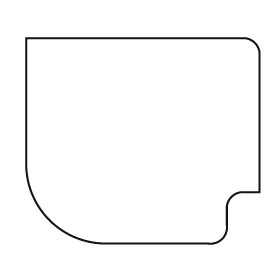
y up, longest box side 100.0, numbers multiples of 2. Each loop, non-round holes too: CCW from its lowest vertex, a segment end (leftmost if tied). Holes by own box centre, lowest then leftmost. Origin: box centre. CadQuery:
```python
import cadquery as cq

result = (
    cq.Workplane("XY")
    .moveTo(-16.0, -44.0)
    .lineTo(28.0, -44.0)
    .threePointArc((34.0, -42.0), (36.0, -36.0))
    .lineTo(36.0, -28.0)
    .threePointArc((38.0, -24.0), (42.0, -22.0))
    .lineTo(50.0, -22.0)
    .lineTo(50.0, 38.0)
    .threePointArc((48.0, 42.0), (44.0, 44.0))
    .lineTo(-50.0, 44.0)
    .lineTo(-50.0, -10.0)
    .threePointArc((-40.0, -34.0), (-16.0, -44.0))
    .close()
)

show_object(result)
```